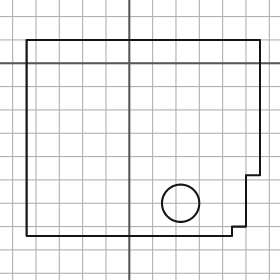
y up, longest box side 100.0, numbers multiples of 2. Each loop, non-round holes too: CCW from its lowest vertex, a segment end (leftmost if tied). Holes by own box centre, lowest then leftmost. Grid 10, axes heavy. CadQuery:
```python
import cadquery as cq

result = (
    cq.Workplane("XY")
    .moveTo(-44.0, -74.0)
    .lineTo(44.0, -74.0)
    .lineTo(44.0, -70.0)
    .lineTo(50.0, -70.0)
    .lineTo(50.0, -48.0)
    .lineTo(56.0, -48.0)
    .lineTo(56.0, 10.0)
    .lineTo(-44.0, 10.0)
    .close()
    .moveTo(22.0, -60.0)
    .circle(8.0)
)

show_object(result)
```